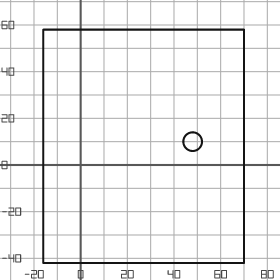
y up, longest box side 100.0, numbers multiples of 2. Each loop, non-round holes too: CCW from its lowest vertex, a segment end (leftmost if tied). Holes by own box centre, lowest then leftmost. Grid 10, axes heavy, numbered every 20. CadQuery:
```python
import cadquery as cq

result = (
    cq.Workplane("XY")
    .moveTo(-16.0, -42.0)
    .lineTo(70.0, -42.0)
    .lineTo(70.0, 58.0)
    .lineTo(-16.0, 58.0)
    .close()
    .moveTo(48.0, 10.0)
    .circle(4.0)
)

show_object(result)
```